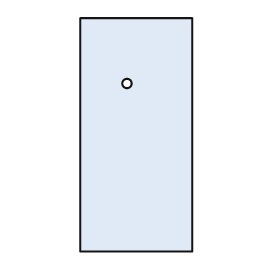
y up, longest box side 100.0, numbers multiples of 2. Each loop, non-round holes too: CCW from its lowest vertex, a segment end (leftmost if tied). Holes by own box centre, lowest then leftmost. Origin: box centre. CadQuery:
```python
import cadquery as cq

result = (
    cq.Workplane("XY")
    .moveTo(-24.0, -50.0)
    .lineTo(24.0, -50.0)
    .lineTo(24.0, 50.0)
    .lineTo(-24.0, 50.0)
    .close()
    .moveTo(-4.0, 22.0)
    .circle(2.0)
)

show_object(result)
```